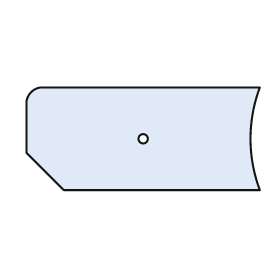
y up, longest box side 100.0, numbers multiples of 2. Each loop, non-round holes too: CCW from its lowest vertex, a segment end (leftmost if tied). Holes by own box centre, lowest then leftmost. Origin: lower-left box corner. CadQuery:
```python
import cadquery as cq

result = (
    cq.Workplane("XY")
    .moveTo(16.0, 0.0)
    .lineTo(100.0, 0.0)
    .threePointArc((96.0, 22.0), (100.0, 44.0))
    .lineTo(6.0, 44.0)
    .threePointArc((2.0, 42.0), (0.0, 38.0))
    .lineTo(0.0, 16.0)
    .close()
    .moveTo(50.0, 22.0)
    .circle(2.0)
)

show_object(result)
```